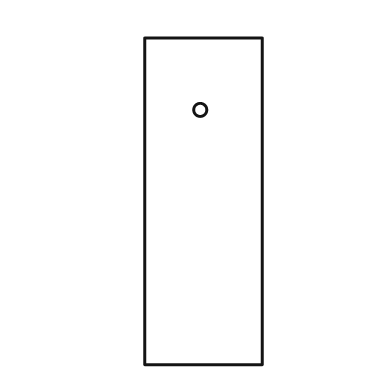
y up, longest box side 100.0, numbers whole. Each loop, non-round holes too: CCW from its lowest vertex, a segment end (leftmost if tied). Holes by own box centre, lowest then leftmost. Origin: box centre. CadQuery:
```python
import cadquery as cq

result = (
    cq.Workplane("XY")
    .moveTo(-18.0, -50.0)
    .lineTo(18.0, -50.0)
    .lineTo(18.0, 50.0)
    .lineTo(-18.0, 50.0)
    .close()
    .moveTo(-1.0, 28.0)
    .circle(2.0)
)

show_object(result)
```